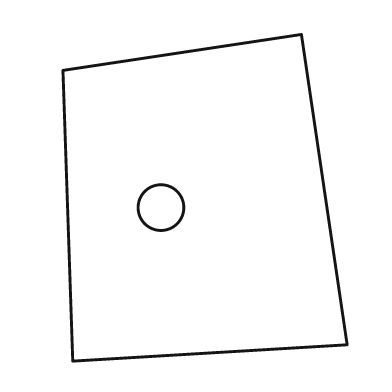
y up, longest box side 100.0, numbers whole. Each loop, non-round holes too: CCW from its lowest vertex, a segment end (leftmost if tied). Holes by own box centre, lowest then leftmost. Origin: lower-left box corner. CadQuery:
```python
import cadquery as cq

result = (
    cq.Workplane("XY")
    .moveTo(3.0, 0.0)
    .lineTo(87.0, 5.0)
    .lineTo(73.0, 100.0)
    .lineTo(0.0, 89.0)
    .close()
    .moveTo(30.0, 47.0)
    .circle(7.0)
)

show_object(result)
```